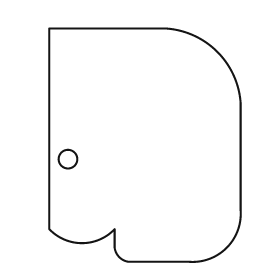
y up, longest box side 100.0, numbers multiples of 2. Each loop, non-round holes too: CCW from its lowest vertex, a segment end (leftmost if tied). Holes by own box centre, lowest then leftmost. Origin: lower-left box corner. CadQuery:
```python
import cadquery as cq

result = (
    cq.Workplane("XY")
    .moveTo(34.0, 0.0)
    .lineTo(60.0, 0.0)
    .threePointArc((76.0, 6.0), (82.0, 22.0))
    .lineTo(82.0, 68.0)
    .threePointArc((72.0, 90.0), (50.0, 100.0))
    .lineTo(0.0, 100.0)
    .lineTo(0.0, 14.0)
    .threePointArc((14.0, 8.0), (28.0, 14.0))
    .lineTo(28.0, 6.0)
    .threePointArc((30.0, 2.0), (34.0, 0.0))
    .close()
    .moveTo(8.0, 44.0)
    .circle(4.0)
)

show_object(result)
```